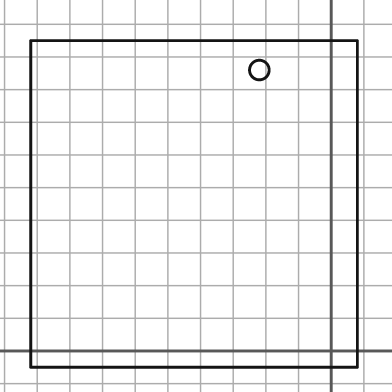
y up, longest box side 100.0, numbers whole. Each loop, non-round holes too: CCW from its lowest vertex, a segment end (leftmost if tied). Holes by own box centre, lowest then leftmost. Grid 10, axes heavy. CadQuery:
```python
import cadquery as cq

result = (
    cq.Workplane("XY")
    .moveTo(-92.0, -5.0)
    .lineTo(8.0, -5.0)
    .lineTo(8.0, 95.0)
    .lineTo(-92.0, 95.0)
    .close()
    .moveTo(-22.0, 86.0)
    .circle(3.0)
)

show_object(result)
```